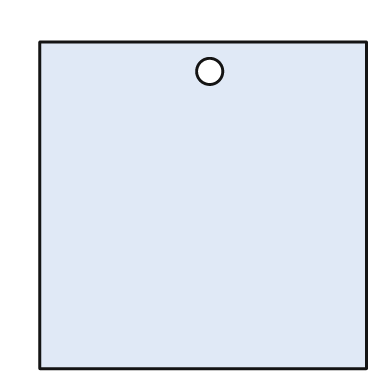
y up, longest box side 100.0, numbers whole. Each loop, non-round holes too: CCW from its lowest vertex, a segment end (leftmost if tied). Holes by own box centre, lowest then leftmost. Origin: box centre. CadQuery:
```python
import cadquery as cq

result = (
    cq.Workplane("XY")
    .moveTo(-50.0, -50.0)
    .lineTo(50.0, -50.0)
    .lineTo(50.0, 50.0)
    .lineTo(-50.0, 50.0)
    .close()
    .moveTo(2.0, 41.0)
    .circle(4.0)
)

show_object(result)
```